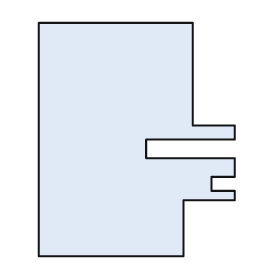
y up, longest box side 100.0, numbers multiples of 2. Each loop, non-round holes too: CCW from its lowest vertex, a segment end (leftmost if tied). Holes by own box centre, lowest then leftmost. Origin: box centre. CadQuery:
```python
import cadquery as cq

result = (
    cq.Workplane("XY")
    .moveTo(-42.0, -50.0)
    .lineTo(20.0, -50.0)
    .lineTo(20.0, -26.0)
    .lineTo(42.0, -26.0)
    .lineTo(42.0, -22.0)
    .lineTo(32.0, -22.0)
    .lineTo(32.0, -16.0)
    .lineTo(42.0, -16.0)
    .lineTo(42.0, -8.0)
    .lineTo(4.0, -8.0)
    .lineTo(4.0, 0.0)
    .lineTo(42.0, 0.0)
    .lineTo(42.0, 6.0)
    .lineTo(24.0, 6.0)
    .lineTo(24.0, 50.0)
    .lineTo(-42.0, 50.0)
    .close()
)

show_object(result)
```